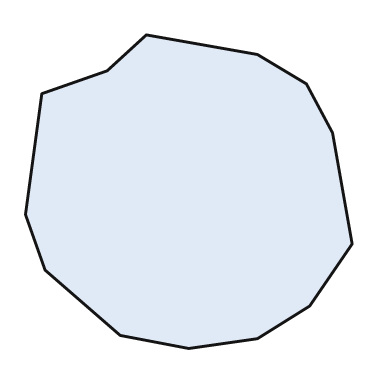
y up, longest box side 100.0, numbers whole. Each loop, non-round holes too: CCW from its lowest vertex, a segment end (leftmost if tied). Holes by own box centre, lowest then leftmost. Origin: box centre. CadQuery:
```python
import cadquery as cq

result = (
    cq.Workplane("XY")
    .moveTo(0.0, -48.0)
    .lineTo(21.0, -45.0)
    .lineTo(37.0, -35.0)
    .lineTo(50.0, -16.0)
    .lineTo(44.0, 18.0)
    .lineTo(36.0, 33.0)
    .lineTo(21.0, 42.0)
    .lineTo(-13.0, 48.0)
    .lineTo(-25.0, 37.0)
    .lineTo(-45.0, 30.0)
    .lineTo(-50.0, -7.0)
    .lineTo(-44.0, -24.0)
    .lineTo(-21.0, -44.0)
    .close()
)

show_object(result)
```